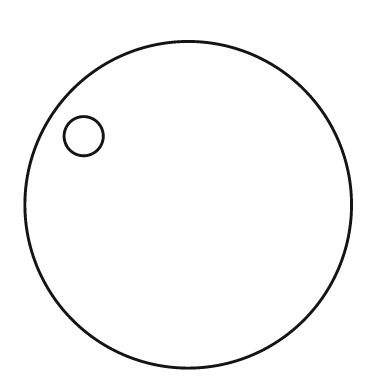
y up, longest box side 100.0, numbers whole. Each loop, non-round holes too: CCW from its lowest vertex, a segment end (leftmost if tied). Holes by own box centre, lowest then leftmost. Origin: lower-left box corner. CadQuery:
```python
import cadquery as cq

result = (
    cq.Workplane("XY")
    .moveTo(50.0, 50.0)
    .circle(50.0)
    .moveTo(18.0, 71.0)
    .circle(6.0)
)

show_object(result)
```